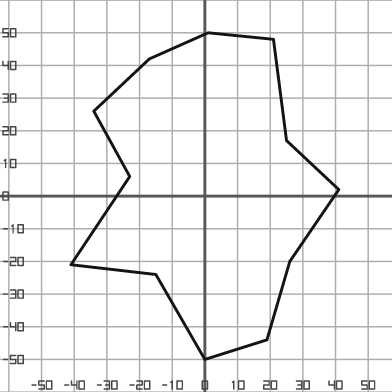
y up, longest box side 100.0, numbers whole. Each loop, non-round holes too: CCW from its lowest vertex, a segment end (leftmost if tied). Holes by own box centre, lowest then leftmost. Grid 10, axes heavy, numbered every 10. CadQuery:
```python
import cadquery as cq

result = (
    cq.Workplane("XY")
    .moveTo(0.0, -50.0)
    .lineTo(19.0, -44.0)
    .lineTo(26.0, -20.0)
    .lineTo(41.0, 2.0)
    .lineTo(25.0, 17.0)
    .lineTo(21.0, 48.0)
    .lineTo(1.0, 50.0)
    .lineTo(-17.0, 42.0)
    .lineTo(-34.0, 26.0)
    .lineTo(-23.0, 6.0)
    .lineTo(-41.0, -21.0)
    .lineTo(-15.0, -24.0)
    .close()
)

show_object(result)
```